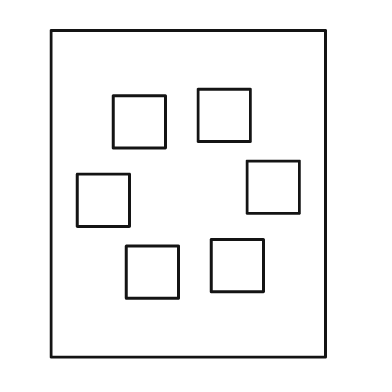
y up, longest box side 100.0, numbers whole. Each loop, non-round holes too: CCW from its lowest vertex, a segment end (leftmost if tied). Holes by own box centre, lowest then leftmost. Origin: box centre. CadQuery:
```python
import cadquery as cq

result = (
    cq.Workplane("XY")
    .moveTo(-42.0, -50.0)
    .lineTo(42.0, -50.0)
    .lineTo(42.0, 50.0)
    .lineTo(-42.0, 50.0)
    .close()
    .moveTo(-19.0, -32.0)
    .lineTo(-3.0, -32.0)
    .lineTo(-3.0, -16.0)
    .lineTo(-19.0, -16.0)
    .close()
    .moveTo(7.0, -30.0)
    .lineTo(23.0, -30.0)
    .lineTo(23.0, -14.0)
    .lineTo(7.0, -14.0)
    .close()
    .moveTo(-34.0, -10.0)
    .lineTo(-18.0, -10.0)
    .lineTo(-18.0, 6.0)
    .lineTo(-34.0, 6.0)
    .close()
    .moveTo(18.0, -6.0)
    .lineTo(34.0, -6.0)
    .lineTo(34.0, 10.0)
    .lineTo(18.0, 10.0)
    .close()
    .moveTo(-23.0, 14.0)
    .lineTo(-7.0, 14.0)
    .lineTo(-7.0, 30.0)
    .lineTo(-23.0, 30.0)
    .close()
    .moveTo(3.0, 16.0)
    .lineTo(19.0, 16.0)
    .lineTo(19.0, 32.0)
    .lineTo(3.0, 32.0)
    .close()
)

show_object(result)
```